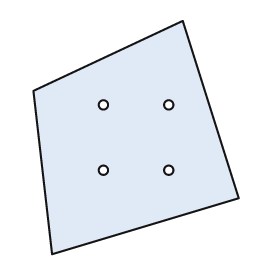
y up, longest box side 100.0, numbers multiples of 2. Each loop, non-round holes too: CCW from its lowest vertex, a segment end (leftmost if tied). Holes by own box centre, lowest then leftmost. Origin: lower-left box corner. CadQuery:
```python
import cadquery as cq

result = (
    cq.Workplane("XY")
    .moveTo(8.0, 0.0)
    .lineTo(88.0, 24.0)
    .lineTo(64.0, 100.0)
    .lineTo(0.0, 70.0)
    .close()
    .moveTo(30.0, 36.0)
    .circle(2.0)
    .moveTo(58.0, 36.0)
    .circle(2.0)
    .moveTo(30.0, 64.0)
    .circle(2.0)
    .moveTo(58.0, 64.0)
    .circle(2.0)
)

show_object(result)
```